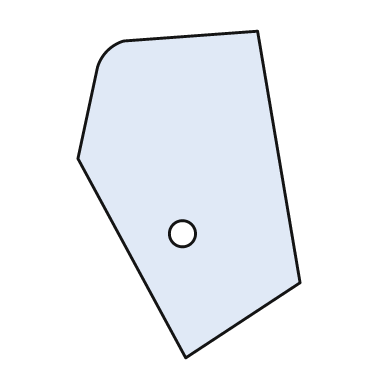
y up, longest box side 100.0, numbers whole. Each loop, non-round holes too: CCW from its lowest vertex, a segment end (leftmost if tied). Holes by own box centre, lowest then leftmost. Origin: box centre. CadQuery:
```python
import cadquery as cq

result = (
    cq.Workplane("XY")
    .moveTo(-1.0, -50.0)
    .lineTo(34.0, -27.0)
    .lineTo(21.0, 50.0)
    .lineTo(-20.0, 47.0)
    .threePointArc((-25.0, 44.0), (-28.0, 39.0))
    .lineTo(-34.0, 11.0)
    .close()
    .moveTo(-2.0, -12.0)
    .circle(4.0)
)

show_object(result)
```